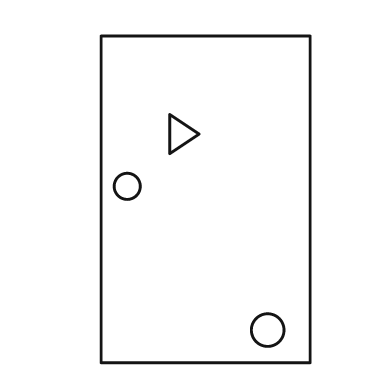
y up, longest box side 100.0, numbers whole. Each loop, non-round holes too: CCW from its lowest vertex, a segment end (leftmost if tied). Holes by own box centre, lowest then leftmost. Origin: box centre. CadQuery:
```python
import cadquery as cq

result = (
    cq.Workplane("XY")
    .moveTo(-32.0, -50.0)
    .lineTo(32.0, -50.0)
    .lineTo(32.0, 50.0)
    .lineTo(-32.0, 50.0)
    .close()
    .moveTo(19.0, -40.0)
    .circle(5.0)
    .moveTo(-24.0, 4.0)
    .circle(4.0)
    .moveTo(-11.0, 14.0)
    .lineTo(-2.0, 20.0)
    .lineTo(-11.0, 26.0)
    .close()
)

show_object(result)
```